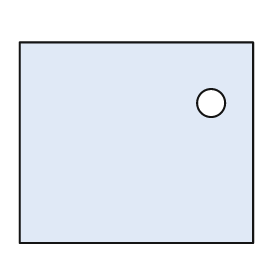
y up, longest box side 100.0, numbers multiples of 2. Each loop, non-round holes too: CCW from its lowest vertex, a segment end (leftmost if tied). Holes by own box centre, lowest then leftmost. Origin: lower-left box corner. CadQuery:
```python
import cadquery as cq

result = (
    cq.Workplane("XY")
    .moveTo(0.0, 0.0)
    .lineTo(100.0, 0.0)
    .lineTo(100.0, 86.0)
    .lineTo(0.0, 86.0)
    .close()
    .moveTo(82.0, 60.0)
    .circle(6.0)
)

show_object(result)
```